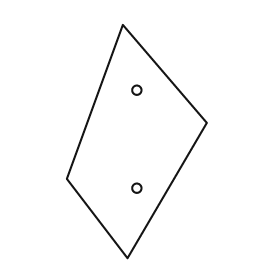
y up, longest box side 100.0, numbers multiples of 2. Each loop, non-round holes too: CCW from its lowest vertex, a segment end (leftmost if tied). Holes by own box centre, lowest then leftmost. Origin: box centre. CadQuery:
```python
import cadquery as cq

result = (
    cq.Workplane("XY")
    .moveTo(-4.0, -50.0)
    .lineTo(30.0, 8.0)
    .lineTo(-6.0, 50.0)
    .lineTo(-30.0, -16.0)
    .close()
    .moveTo(0.0, -20.0)
    .circle(2.0)
    .moveTo(0.0, 22.0)
    .circle(2.0)
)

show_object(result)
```